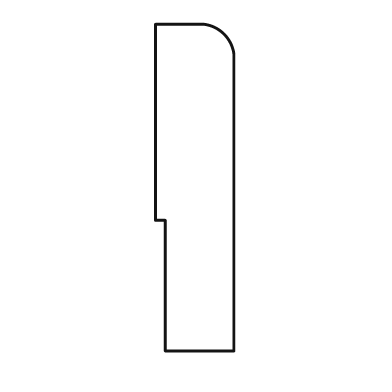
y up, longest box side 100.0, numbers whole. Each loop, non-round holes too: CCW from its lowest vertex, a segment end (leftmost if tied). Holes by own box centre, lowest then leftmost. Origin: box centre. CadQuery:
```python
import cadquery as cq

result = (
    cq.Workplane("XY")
    .moveTo(-9.0, -50.0)
    .lineTo(12.0, -50.0)
    .lineTo(12.0, 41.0)
    .threePointArc((9.0, 47.0), (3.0, 50.0))
    .lineTo(-12.0, 50.0)
    .lineTo(-12.0, -10.0)
    .lineTo(-9.0, -10.0)
    .close()
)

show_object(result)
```